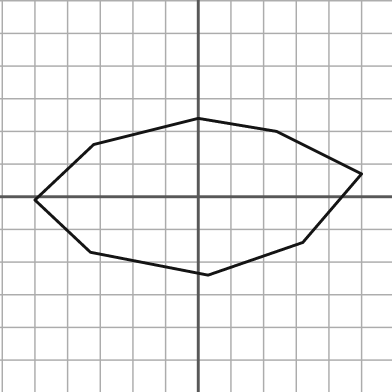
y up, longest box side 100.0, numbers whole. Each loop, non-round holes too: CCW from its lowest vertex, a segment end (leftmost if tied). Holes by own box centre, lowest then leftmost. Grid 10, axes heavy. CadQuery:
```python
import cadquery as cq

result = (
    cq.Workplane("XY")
    .moveTo(3.0, -24.0)
    .lineTo(32.0, -14.0)
    .lineTo(50.0, 7.0)
    .lineTo(24.0, 20.0)
    .lineTo(0.0, 24.0)
    .lineTo(-32.0, 16.0)
    .lineTo(-50.0, -1.0)
    .lineTo(-33.0, -17.0)
    .close()
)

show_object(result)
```